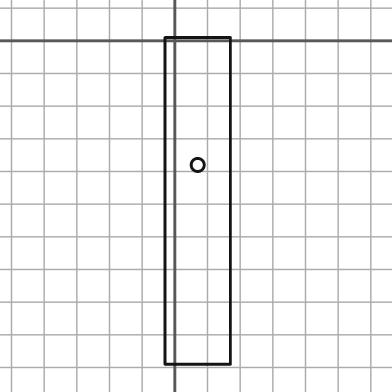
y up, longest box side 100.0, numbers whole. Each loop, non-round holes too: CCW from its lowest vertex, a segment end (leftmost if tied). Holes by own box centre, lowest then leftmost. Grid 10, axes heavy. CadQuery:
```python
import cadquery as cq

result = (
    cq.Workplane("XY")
    .moveTo(-3.0, -99.0)
    .lineTo(17.0, -99.0)
    .lineTo(17.0, 1.0)
    .lineTo(-3.0, 1.0)
    .close()
    .moveTo(7.0, -38.0)
    .circle(2.0)
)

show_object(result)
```